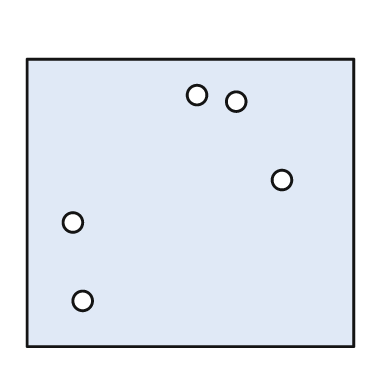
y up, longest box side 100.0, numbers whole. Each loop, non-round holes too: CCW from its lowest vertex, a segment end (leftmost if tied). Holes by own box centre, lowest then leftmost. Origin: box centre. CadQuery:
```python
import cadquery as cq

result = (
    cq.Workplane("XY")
    .moveTo(-50.0, -44.0)
    .lineTo(50.0, -44.0)
    .lineTo(50.0, 44.0)
    .lineTo(-50.0, 44.0)
    .close()
    .moveTo(-33.0, -30.0)
    .circle(3.0)
    .moveTo(-36.0, -6.0)
    .circle(3.0)
    .moveTo(28.0, 7.0)
    .circle(3.0)
    .moveTo(14.0, 31.0)
    .circle(3.0)
    .moveTo(2.0, 33.0)
    .circle(3.0)
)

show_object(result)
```